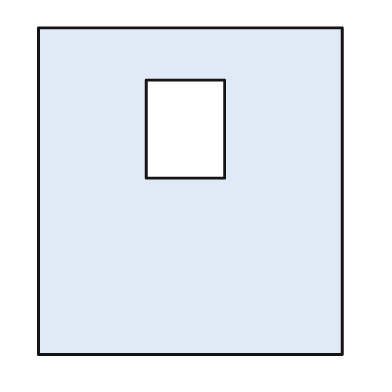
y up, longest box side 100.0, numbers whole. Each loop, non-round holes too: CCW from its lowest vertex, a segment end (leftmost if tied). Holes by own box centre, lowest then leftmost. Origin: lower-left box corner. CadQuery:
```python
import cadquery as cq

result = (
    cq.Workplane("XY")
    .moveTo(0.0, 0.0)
    .lineTo(93.0, 0.0)
    .lineTo(93.0, 100.0)
    .lineTo(0.0, 100.0)
    .close()
    .moveTo(33.0, 54.0)
    .lineTo(57.0, 54.0)
    .lineTo(57.0, 84.0)
    .lineTo(33.0, 84.0)
    .close()
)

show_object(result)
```